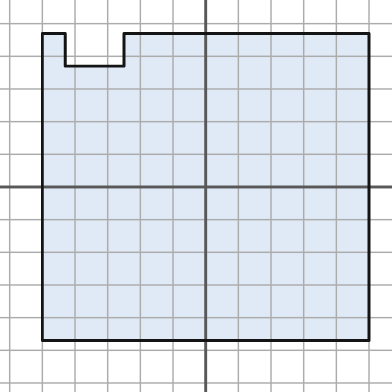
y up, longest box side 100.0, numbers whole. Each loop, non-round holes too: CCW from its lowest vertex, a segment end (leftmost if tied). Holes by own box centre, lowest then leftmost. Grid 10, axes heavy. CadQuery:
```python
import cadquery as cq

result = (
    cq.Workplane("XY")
    .moveTo(-50.0, -47.0)
    .lineTo(50.0, -47.0)
    .lineTo(50.0, 47.0)
    .lineTo(-25.0, 47.0)
    .lineTo(-25.0, 37.0)
    .lineTo(-43.0, 37.0)
    .lineTo(-43.0, 47.0)
    .lineTo(-50.0, 47.0)
    .close()
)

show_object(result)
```